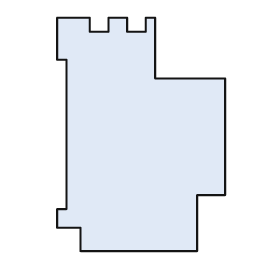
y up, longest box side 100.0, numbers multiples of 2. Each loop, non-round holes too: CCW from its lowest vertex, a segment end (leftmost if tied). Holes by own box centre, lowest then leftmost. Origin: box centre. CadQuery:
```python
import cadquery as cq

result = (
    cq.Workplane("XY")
    .moveTo(-26.0, -50.0)
    .lineTo(24.0, -50.0)
    .lineTo(24.0, -26.0)
    .lineTo(36.0, -26.0)
    .lineTo(36.0, 24.0)
    .lineTo(6.0, 24.0)
    .lineTo(6.0, 50.0)
    .lineTo(2.0, 50.0)
    .lineTo(2.0, 44.0)
    .lineTo(-6.0, 44.0)
    .lineTo(-6.0, 50.0)
    .lineTo(-14.0, 50.0)
    .lineTo(-14.0, 44.0)
    .lineTo(-22.0, 44.0)
    .lineTo(-22.0, 50.0)
    .lineTo(-36.0, 50.0)
    .lineTo(-36.0, 32.0)
    .lineTo(-32.0, 32.0)
    .lineTo(-32.0, -32.0)
    .lineTo(-36.0, -32.0)
    .lineTo(-36.0, -40.0)
    .lineTo(-26.0, -40.0)
    .close()
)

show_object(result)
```